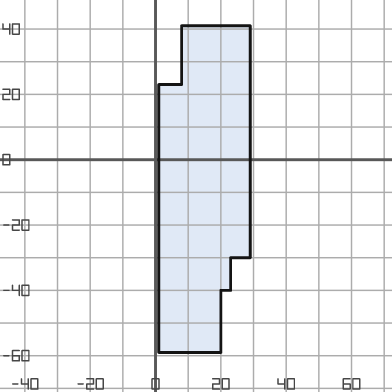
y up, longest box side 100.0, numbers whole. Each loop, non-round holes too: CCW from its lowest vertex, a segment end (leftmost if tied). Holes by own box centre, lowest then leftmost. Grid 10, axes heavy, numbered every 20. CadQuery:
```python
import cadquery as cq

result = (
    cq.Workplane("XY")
    .moveTo(1.0, -59.0)
    .lineTo(20.0, -59.0)
    .lineTo(20.0, -40.0)
    .lineTo(23.0, -40.0)
    .lineTo(23.0, -30.0)
    .lineTo(29.0, -30.0)
    .lineTo(29.0, 41.0)
    .lineTo(8.0, 41.0)
    .lineTo(8.0, 23.0)
    .lineTo(1.0, 23.0)
    .close()
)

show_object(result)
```